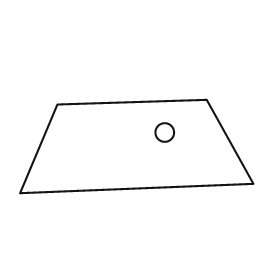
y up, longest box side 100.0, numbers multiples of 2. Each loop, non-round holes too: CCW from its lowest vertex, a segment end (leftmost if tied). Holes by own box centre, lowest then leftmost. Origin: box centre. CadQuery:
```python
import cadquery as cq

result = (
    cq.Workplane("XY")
    .moveTo(-50.0, -20.0)
    .lineTo(50.0, -16.0)
    .lineTo(30.0, 20.0)
    .lineTo(-34.0, 18.0)
    .close()
    .moveTo(12.0, 6.0)
    .circle(4.0)
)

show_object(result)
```